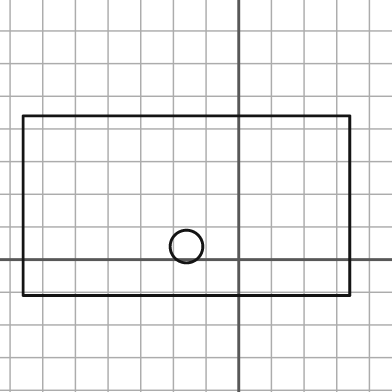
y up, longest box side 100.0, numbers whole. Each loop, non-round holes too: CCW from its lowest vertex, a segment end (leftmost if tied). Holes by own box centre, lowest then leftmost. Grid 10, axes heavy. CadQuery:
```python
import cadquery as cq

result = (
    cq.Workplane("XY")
    .moveTo(-66.0, -11.0)
    .lineTo(34.0, -11.0)
    .lineTo(34.0, 44.0)
    .lineTo(-66.0, 44.0)
    .close()
    .moveTo(-16.0, 4.0)
    .circle(5.0)
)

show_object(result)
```